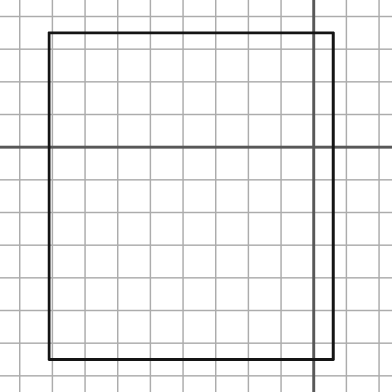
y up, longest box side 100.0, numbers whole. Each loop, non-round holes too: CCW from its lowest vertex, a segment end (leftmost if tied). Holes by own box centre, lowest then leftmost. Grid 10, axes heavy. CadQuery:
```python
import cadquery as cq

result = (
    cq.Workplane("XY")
    .moveTo(-81.0, -65.0)
    .lineTo(6.0, -65.0)
    .lineTo(6.0, 35.0)
    .lineTo(-81.0, 35.0)
    .close()
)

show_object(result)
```